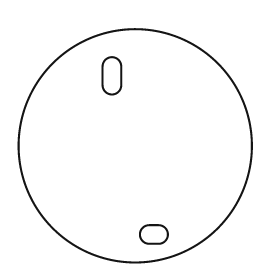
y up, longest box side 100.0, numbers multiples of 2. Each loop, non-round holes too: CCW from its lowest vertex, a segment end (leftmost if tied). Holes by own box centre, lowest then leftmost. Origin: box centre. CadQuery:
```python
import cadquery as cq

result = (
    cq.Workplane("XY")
    .moveTo(0.0, 0.0)
    .circle(50.0)
    .moveTo(6.0, -42.0)
    .lineTo(10.0, -42.0)
    .threePointArc((14.0, -38.0), (10.0, -34.0))
    .lineTo(6.0, -34.0)
    .threePointArc((2.0, -38.0), (6.0, -42.0))
    .close()
    .moveTo(-14.0, 26.0)
    .threePointArc((-10.0, 22.0), (-6.0, 26.0))
    .lineTo(-6.0, 34.0)
    .threePointArc((-10.0, 38.0), (-14.0, 34.0))
    .close()
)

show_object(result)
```